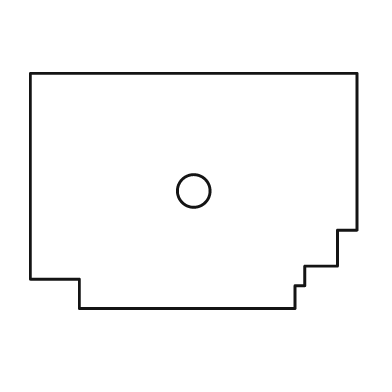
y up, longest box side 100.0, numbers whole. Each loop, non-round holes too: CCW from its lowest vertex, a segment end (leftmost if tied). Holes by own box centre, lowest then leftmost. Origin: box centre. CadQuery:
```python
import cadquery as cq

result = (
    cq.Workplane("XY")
    .moveTo(-35.0, -36.0)
    .lineTo(31.0, -36.0)
    .lineTo(31.0, -29.0)
    .lineTo(34.0, -29.0)
    .lineTo(34.0, -23.0)
    .lineTo(44.0, -23.0)
    .lineTo(44.0, -12.0)
    .lineTo(50.0, -12.0)
    .lineTo(50.0, 36.0)
    .lineTo(-50.0, 36.0)
    .lineTo(-50.0, -27.0)
    .lineTo(-35.0, -27.0)
    .close()
    .moveTo(0.0, 0.0)
    .circle(5.0)
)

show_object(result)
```